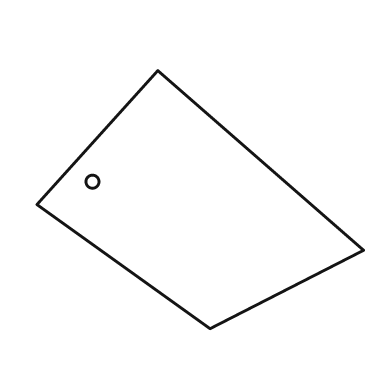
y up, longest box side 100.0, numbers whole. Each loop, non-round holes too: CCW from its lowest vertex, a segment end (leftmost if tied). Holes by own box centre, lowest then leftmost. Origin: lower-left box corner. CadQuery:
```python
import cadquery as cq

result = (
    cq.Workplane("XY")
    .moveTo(53.0, 0.0)
    .lineTo(100.0, 24.0)
    .lineTo(37.0, 79.0)
    .lineTo(0.0, 38.0)
    .close()
    .moveTo(17.0, 45.0)
    .circle(2.0)
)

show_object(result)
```